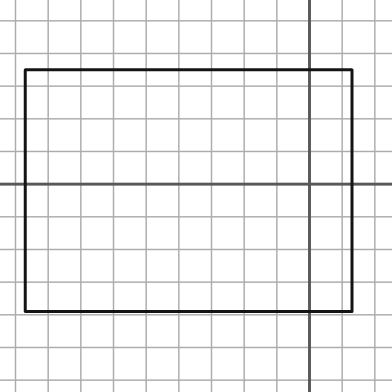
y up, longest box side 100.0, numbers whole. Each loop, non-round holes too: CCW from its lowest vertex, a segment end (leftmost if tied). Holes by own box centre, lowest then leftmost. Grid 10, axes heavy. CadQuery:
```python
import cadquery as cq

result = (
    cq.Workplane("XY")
    .moveTo(-87.0, -39.0)
    .lineTo(13.0, -39.0)
    .lineTo(13.0, 35.0)
    .lineTo(-87.0, 35.0)
    .close()
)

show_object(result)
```